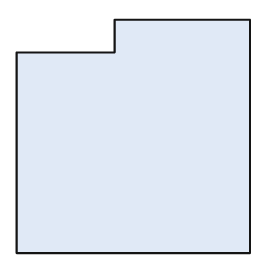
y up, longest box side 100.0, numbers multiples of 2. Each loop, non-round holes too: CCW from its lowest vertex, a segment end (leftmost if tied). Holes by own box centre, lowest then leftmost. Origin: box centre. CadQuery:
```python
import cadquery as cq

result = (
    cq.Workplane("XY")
    .moveTo(-50.0, -50.0)
    .lineTo(50.0, -50.0)
    .lineTo(50.0, 50.0)
    .lineTo(-8.0, 50.0)
    .lineTo(-8.0, 36.0)
    .lineTo(-50.0, 36.0)
    .close()
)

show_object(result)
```